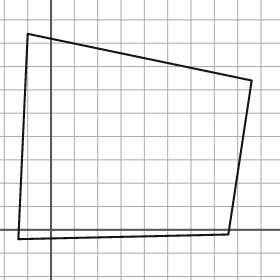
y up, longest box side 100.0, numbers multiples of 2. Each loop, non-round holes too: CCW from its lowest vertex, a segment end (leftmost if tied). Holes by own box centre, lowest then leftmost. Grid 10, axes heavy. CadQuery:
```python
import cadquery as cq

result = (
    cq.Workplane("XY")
    .moveTo(-14.0, -4.0)
    .lineTo(76.0, -2.0)
    .lineTo(86.0, 64.0)
    .lineTo(-10.0, 84.0)
    .close()
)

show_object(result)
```